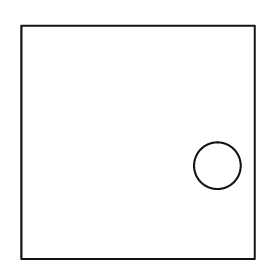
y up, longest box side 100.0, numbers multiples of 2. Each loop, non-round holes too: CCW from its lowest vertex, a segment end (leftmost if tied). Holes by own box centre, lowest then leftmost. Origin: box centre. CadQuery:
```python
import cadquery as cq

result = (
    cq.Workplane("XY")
    .moveTo(-50.0, -50.0)
    .lineTo(50.0, -50.0)
    .lineTo(50.0, 50.0)
    .lineTo(-50.0, 50.0)
    .close()
    .moveTo(34.0, -10.0)
    .circle(10.0)
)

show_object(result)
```